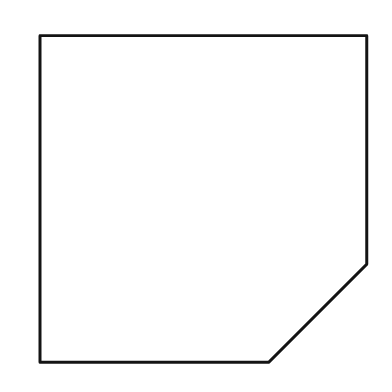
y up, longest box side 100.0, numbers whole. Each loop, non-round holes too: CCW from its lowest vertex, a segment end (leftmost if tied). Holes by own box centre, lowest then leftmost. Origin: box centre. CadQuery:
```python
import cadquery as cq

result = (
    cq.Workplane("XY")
    .moveTo(-50.0, -50.0)
    .lineTo(20.0, -50.0)
    .lineTo(50.0, -20.0)
    .lineTo(50.0, 50.0)
    .lineTo(-50.0, 50.0)
    .close()
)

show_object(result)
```